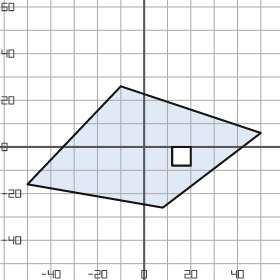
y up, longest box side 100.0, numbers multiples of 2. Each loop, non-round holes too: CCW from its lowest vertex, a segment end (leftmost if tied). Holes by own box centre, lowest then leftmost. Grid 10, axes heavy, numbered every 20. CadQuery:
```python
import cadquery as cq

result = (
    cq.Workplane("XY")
    .moveTo(8.0, -26.0)
    .lineTo(50.0, 6.0)
    .lineTo(-10.0, 26.0)
    .lineTo(-50.0, -16.0)
    .close()
    .moveTo(12.0, -8.0)
    .lineTo(20.0, -8.0)
    .lineTo(20.0, 0.0)
    .lineTo(12.0, 0.0)
    .close()
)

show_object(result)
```